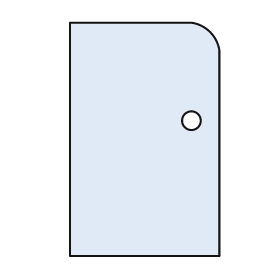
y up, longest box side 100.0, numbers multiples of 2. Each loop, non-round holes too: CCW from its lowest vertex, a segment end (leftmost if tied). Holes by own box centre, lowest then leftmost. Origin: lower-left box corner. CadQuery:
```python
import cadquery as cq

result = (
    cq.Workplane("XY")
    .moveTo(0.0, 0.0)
    .lineTo(64.0, 0.0)
    .lineTo(64.0, 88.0)
    .threePointArc((60.0, 96.0), (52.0, 100.0))
    .lineTo(0.0, 100.0)
    .close()
    .moveTo(52.0, 58.0)
    .circle(4.0)
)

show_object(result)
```